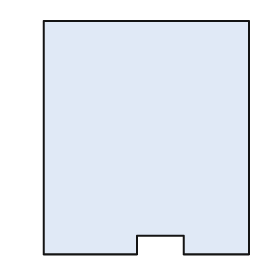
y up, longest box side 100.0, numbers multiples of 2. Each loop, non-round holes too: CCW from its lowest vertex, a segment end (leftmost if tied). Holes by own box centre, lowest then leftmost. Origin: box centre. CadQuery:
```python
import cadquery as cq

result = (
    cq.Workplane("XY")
    .moveTo(-44.0, -50.0)
    .lineTo(-4.0, -50.0)
    .lineTo(-4.0, -42.0)
    .lineTo(16.0, -42.0)
    .lineTo(16.0, -50.0)
    .lineTo(44.0, -50.0)
    .lineTo(44.0, 50.0)
    .lineTo(-44.0, 50.0)
    .close()
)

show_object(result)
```